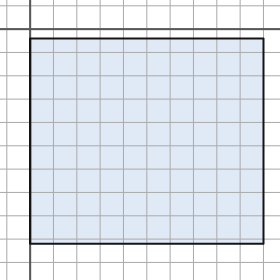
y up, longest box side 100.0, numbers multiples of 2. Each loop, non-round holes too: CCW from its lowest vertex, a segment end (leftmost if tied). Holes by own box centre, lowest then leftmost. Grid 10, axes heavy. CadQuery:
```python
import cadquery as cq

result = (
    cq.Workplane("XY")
    .moveTo(0.0, -92.0)
    .lineTo(100.0, -92.0)
    .lineTo(100.0, -4.0)
    .lineTo(0.0, -4.0)
    .close()
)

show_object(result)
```